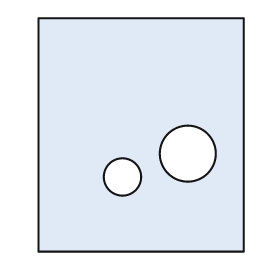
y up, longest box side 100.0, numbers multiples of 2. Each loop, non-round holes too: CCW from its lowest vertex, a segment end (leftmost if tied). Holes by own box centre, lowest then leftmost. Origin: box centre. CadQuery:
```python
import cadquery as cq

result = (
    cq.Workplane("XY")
    .moveTo(-44.0, -50.0)
    .lineTo(44.0, -50.0)
    .lineTo(44.0, 50.0)
    .lineTo(-44.0, 50.0)
    .close()
    .moveTo(-8.0, -18.0)
    .circle(8.0)
    .moveTo(20.0, -8.0)
    .circle(12.0)
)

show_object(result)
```